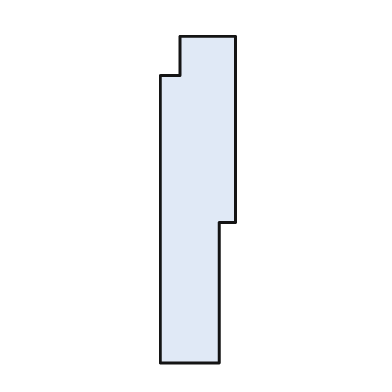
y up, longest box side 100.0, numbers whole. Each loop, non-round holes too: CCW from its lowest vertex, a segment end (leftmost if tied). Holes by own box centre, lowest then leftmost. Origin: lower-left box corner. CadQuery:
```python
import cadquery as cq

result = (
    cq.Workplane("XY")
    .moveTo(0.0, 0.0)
    .lineTo(18.0, 0.0)
    .lineTo(18.0, 43.0)
    .lineTo(23.0, 43.0)
    .lineTo(23.0, 100.0)
    .lineTo(6.0, 100.0)
    .lineTo(6.0, 88.0)
    .lineTo(0.0, 88.0)
    .close()
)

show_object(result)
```